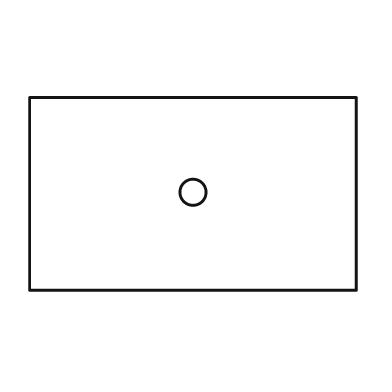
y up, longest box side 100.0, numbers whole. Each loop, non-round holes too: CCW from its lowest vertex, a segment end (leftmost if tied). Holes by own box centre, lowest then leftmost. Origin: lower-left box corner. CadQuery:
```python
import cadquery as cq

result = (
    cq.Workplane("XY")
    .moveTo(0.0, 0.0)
    .lineTo(100.0, 0.0)
    .lineTo(100.0, 59.0)
    .lineTo(0.0, 59.0)
    .close()
    .moveTo(50.0, 30.0)
    .circle(4.0)
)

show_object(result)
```